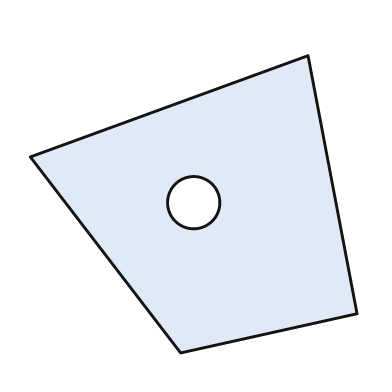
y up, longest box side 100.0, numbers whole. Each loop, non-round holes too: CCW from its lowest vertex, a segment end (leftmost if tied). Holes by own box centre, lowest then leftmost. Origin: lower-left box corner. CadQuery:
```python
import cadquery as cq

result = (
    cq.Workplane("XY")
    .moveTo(46.0, 0.0)
    .lineTo(100.0, 12.0)
    .lineTo(85.0, 91.0)
    .lineTo(0.0, 60.0)
    .close()
    .moveTo(50.0, 46.0)
    .circle(8.0)
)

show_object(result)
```